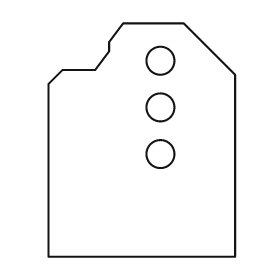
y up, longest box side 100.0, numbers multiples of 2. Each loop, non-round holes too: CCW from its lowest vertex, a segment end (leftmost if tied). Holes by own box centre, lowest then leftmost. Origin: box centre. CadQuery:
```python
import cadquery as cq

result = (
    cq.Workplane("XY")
    .moveTo(-40.0, -50.0)
    .lineTo(40.0, -50.0)
    .lineTo(40.0, 28.0)
    .lineTo(18.0, 50.0)
    .lineTo(-8.0, 50.0)
    .lineTo(-14.0, 42.0)
    .lineTo(-14.0, 38.0)
    .lineTo(-20.0, 30.0)
    .lineTo(-34.0, 30.0)
    .lineTo(-40.0, 24.0)
    .close()
    .moveTo(8.0, -6.0)
    .circle(6.0)
    .moveTo(8.0, 14.0)
    .circle(6.0)
    .moveTo(8.0, 34.0)
    .circle(6.0)
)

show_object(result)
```